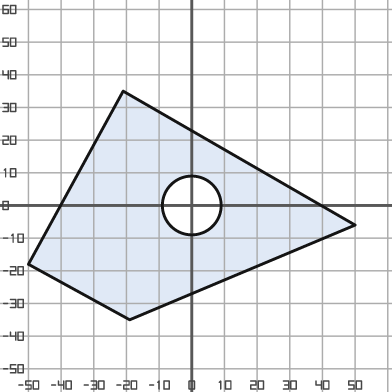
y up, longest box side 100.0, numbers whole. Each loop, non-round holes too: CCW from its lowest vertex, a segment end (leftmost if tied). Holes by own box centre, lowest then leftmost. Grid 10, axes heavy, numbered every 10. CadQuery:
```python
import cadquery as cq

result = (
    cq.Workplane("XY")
    .moveTo(-19.0, -35.0)
    .lineTo(50.0, -6.0)
    .lineTo(-21.0, 35.0)
    .lineTo(-50.0, -18.0)
    .close()
    .moveTo(0.0, 0.0)
    .circle(9.0)
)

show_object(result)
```